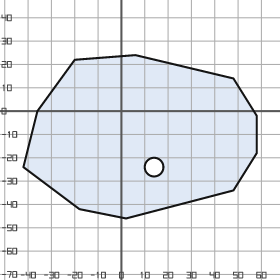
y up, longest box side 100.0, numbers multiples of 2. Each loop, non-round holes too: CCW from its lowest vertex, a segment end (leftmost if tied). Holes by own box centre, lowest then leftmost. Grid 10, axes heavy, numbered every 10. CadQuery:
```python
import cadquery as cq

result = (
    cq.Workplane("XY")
    .moveTo(2.0, -46.0)
    .lineTo(48.0, -34.0)
    .lineTo(58.0, -18.0)
    .lineTo(58.0, -2.0)
    .lineTo(48.0, 14.0)
    .lineTo(6.0, 24.0)
    .lineTo(-20.0, 22.0)
    .lineTo(-36.0, 0.0)
    .lineTo(-42.0, -24.0)
    .lineTo(-18.0, -42.0)
    .close()
    .moveTo(14.0, -24.0)
    .circle(4.0)
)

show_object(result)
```